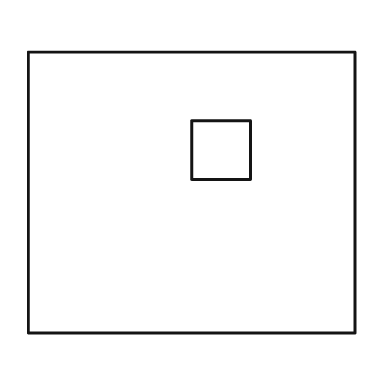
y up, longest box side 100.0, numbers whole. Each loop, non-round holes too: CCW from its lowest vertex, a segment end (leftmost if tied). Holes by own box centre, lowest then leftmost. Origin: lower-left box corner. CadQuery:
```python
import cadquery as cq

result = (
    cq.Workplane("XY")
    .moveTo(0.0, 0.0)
    .lineTo(100.0, 0.0)
    .lineTo(100.0, 86.0)
    .lineTo(0.0, 86.0)
    .close()
    .moveTo(50.0, 47.0)
    .lineTo(68.0, 47.0)
    .lineTo(68.0, 65.0)
    .lineTo(50.0, 65.0)
    .close()
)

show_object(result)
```